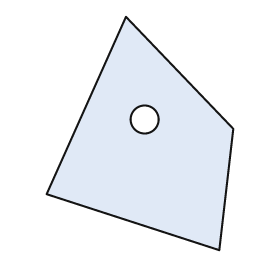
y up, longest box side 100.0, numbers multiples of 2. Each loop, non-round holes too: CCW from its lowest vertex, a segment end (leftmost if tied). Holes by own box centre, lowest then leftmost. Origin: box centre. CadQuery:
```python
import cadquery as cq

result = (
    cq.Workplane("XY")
    .moveTo(34.0, -50.0)
    .lineTo(40.0, 2.0)
    .lineTo(-6.0, 50.0)
    .lineTo(-40.0, -26.0)
    .close()
    .moveTo(2.0, 6.0)
    .circle(6.0)
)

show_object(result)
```